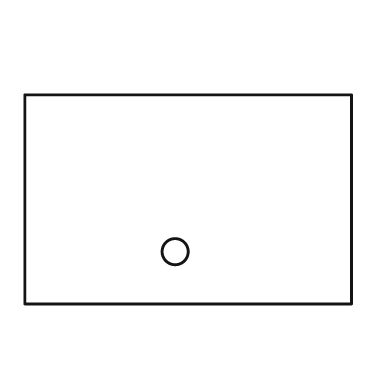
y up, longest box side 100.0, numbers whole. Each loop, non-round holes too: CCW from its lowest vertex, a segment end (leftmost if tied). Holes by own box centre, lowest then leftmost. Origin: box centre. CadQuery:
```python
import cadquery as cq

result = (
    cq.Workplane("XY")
    .moveTo(-50.0, -32.0)
    .lineTo(50.0, -32.0)
    .lineTo(50.0, 32.0)
    .lineTo(-50.0, 32.0)
    .close()
    .moveTo(-4.0, -16.0)
    .circle(4.0)
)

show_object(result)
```